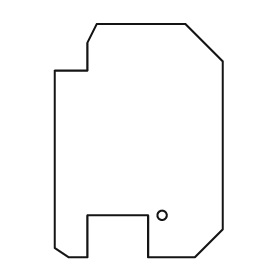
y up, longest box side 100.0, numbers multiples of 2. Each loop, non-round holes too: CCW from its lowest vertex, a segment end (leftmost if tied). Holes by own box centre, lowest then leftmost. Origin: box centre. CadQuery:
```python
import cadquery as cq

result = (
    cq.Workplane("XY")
    .moveTo(-30.0, -50.0)
    .lineTo(-22.0, -50.0)
    .lineTo(-22.0, -32.0)
    .lineTo(4.0, -32.0)
    .lineTo(4.0, -50.0)
    .lineTo(24.0, -50.0)
    .lineTo(36.0, -38.0)
    .lineTo(36.0, 34.0)
    .lineTo(20.0, 50.0)
    .lineTo(-18.0, 50.0)
    .lineTo(-22.0, 42.0)
    .lineTo(-22.0, 30.0)
    .lineTo(-36.0, 30.0)
    .lineTo(-36.0, -46.0)
    .close()
    .moveTo(10.0, -32.0)
    .circle(2.0)
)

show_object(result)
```